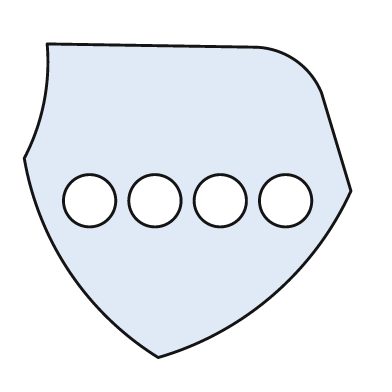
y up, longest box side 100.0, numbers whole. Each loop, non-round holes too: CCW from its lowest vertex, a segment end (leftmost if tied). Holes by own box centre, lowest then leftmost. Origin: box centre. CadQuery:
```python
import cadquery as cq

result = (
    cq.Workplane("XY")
    .moveTo(-9.0, -48.0)
    .threePointArc((26.0, -29.0), (50.0, 3.0))
    .lineTo(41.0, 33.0)
    .threePointArc((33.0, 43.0), (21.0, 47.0))
    .lineTo(-43.0, 48.0)
    .threePointArc((-44.0, 30.0), (-50.0, 13.0))
    .threePointArc((-36.0, -22.0), (-9.0, -48.0))
    .close()
    .moveTo(-30.0, 0.0)
    .circle(8.0)
    .moveTo(-10.0, 0.0)
    .circle(8.0)
    .moveTo(10.0, 0.0)
    .circle(8.0)
    .moveTo(30.0, 0.0)
    .circle(8.0)
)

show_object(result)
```